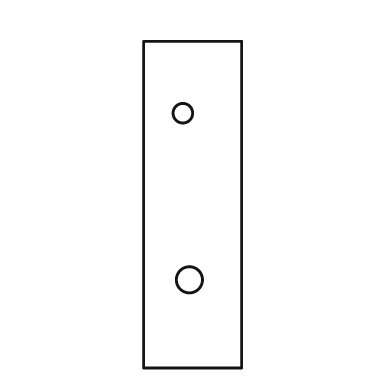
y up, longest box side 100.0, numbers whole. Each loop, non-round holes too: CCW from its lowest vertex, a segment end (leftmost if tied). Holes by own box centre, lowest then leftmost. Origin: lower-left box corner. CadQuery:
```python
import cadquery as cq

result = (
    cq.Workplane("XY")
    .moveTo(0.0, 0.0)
    .lineTo(30.0, 0.0)
    .lineTo(30.0, 100.0)
    .lineTo(0.0, 100.0)
    .close()
    .moveTo(14.0, 27.0)
    .circle(4.0)
    .moveTo(12.0, 78.0)
    .circle(3.0)
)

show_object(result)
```